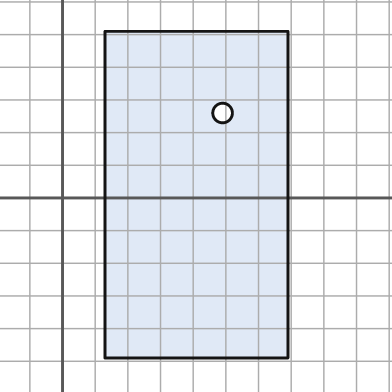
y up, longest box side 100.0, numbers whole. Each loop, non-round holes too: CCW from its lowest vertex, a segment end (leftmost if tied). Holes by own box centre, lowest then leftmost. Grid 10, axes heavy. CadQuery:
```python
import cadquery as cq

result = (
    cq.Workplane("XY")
    .moveTo(13.0, -49.0)
    .lineTo(69.0, -49.0)
    .lineTo(69.0, 51.0)
    .lineTo(13.0, 51.0)
    .close()
    .moveTo(49.0, 26.0)
    .circle(3.0)
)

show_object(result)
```